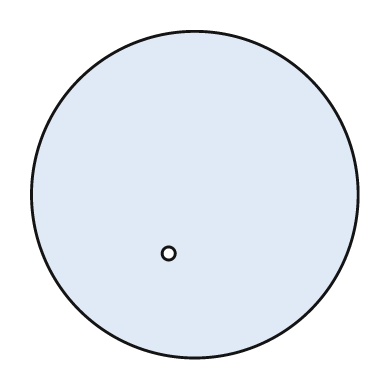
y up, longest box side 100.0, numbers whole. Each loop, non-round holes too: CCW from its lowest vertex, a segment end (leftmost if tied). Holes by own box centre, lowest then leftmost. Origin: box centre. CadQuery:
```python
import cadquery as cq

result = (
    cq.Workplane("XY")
    .moveTo(0.0, 0.0)
    .circle(50.0)
    .moveTo(-8.0, -18.0)
    .circle(2.0)
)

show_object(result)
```